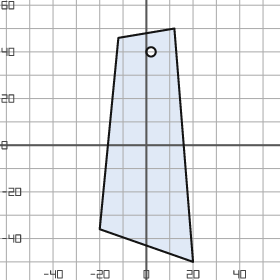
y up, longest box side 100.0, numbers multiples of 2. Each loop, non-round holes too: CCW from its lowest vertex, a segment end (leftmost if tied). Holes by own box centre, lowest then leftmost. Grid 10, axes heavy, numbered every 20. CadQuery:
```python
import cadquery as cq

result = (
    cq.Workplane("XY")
    .moveTo(20.0, -50.0)
    .lineTo(12.0, 50.0)
    .lineTo(-12.0, 46.0)
    .lineTo(-20.0, -36.0)
    .close()
    .moveTo(2.0, 40.0)
    .circle(2.0)
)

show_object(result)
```